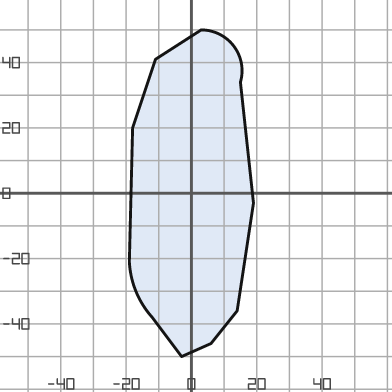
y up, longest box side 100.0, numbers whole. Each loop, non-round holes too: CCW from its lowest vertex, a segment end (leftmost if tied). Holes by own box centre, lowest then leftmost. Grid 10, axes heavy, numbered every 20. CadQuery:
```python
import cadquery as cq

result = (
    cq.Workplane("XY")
    .moveTo(-3.0, -50.0)
    .lineTo(6.0, -46.0)
    .lineTo(14.0, -36.0)
    .lineTo(19.0, -3.0)
    .lineTo(15.0, 34.0)
    .threePointArc((13.0, 45.0), (3.0, 50.0))
    .lineTo(-11.0, 41.0)
    .lineTo(-18.0, 20.0)
    .lineTo(-19.0, -21.0)
    .threePointArc((-17.0, -30.0), (-12.0, -38.0))
    .close()
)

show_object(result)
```